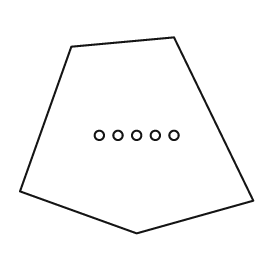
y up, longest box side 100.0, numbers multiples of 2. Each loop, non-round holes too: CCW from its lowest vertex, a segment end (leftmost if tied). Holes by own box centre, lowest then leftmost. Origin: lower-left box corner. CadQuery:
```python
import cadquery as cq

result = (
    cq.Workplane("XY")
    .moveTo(50.0, 0.0)
    .lineTo(100.0, 14.0)
    .lineTo(66.0, 84.0)
    .lineTo(22.0, 80.0)
    .lineTo(0.0, 18.0)
    .close()
    .moveTo(34.0, 42.0)
    .circle(2.0)
    .moveTo(42.0, 42.0)
    .circle(2.0)
    .moveTo(50.0, 42.0)
    .circle(2.0)
    .moveTo(58.0, 42.0)
    .circle(2.0)
    .moveTo(66.0, 42.0)
    .circle(2.0)
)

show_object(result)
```